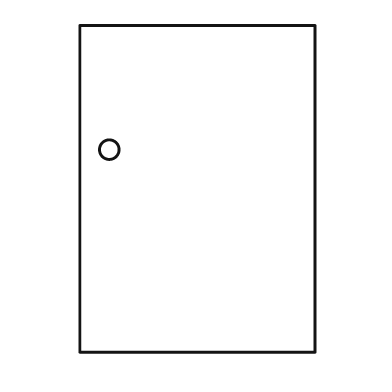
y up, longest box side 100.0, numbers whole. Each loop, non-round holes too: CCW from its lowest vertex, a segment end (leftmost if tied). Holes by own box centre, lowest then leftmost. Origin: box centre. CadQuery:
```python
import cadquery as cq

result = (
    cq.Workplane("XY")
    .moveTo(-36.0, -50.0)
    .lineTo(36.0, -50.0)
    .lineTo(36.0, 50.0)
    .lineTo(-36.0, 50.0)
    .close()
    .moveTo(-27.0, 12.0)
    .circle(3.0)
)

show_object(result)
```